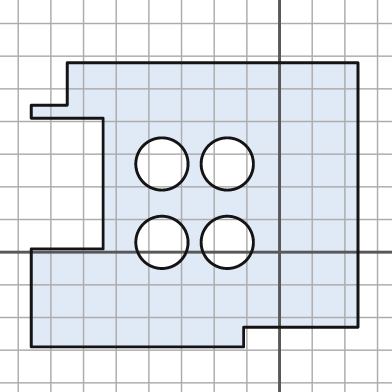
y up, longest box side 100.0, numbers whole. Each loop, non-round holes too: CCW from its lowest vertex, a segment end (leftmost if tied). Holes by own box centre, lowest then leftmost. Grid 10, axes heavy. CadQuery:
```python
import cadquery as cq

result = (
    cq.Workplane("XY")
    .moveTo(-76.0, -29.0)
    .lineTo(-11.0, -29.0)
    .lineTo(-11.0, -23.0)
    .lineTo(24.0, -23.0)
    .lineTo(24.0, 58.0)
    .lineTo(-65.0, 58.0)
    .lineTo(-65.0, 45.0)
    .lineTo(-76.0, 45.0)
    .lineTo(-76.0, 41.0)
    .lineTo(-54.0, 41.0)
    .lineTo(-54.0, 1.0)
    .lineTo(-76.0, 1.0)
    .close()
    .moveTo(-36.0, 3.0)
    .circle(8.0)
    .moveTo(-16.0, 3.0)
    .circle(8.0)
    .moveTo(-36.0, 27.0)
    .circle(8.0)
    .moveTo(-16.0, 27.0)
    .circle(8.0)
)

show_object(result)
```